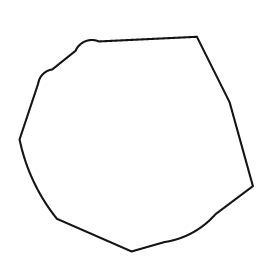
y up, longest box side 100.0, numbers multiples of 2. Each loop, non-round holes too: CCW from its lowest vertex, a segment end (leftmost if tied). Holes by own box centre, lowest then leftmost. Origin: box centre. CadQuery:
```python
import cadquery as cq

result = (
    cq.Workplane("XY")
    .moveTo(-2.0, -46.0)
    .lineTo(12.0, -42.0)
    .threePointArc((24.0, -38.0), (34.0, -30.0))
    .lineTo(50.0, -18.0)
    .lineTo(40.0, 18.0)
    .lineTo(26.0, 46.0)
    .lineTo(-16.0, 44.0)
    .threePointArc((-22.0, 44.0), (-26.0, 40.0))
    .lineTo(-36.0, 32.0)
    .threePointArc((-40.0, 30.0), (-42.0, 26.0))
    .lineTo(-50.0, 2.0)
    .threePointArc((-44.0, -16.0), (-34.0, -32.0))
    .close()
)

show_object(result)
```